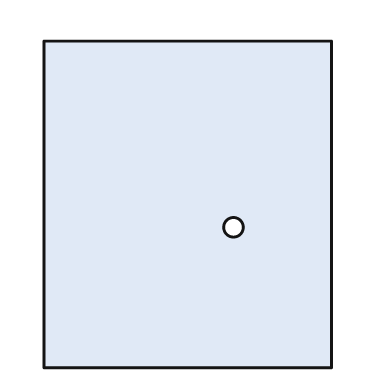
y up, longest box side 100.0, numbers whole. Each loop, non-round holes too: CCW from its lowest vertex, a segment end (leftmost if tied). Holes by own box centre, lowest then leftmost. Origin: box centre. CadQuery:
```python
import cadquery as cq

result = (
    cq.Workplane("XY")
    .moveTo(-44.0, -50.0)
    .lineTo(44.0, -50.0)
    .lineTo(44.0, 50.0)
    .lineTo(-44.0, 50.0)
    .close()
    .moveTo(14.0, -7.0)
    .circle(3.0)
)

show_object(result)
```